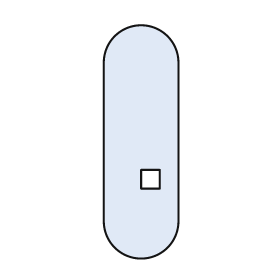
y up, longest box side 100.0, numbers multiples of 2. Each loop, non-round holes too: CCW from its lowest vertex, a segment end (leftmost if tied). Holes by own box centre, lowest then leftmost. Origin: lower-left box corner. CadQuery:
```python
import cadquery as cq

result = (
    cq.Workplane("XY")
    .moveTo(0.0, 16.0)
    .threePointArc((16.0, 0.0), (32.0, 16.0))
    .lineTo(32.0, 84.0)
    .threePointArc((16.0, 100.0), (0.0, 84.0))
    .close()
    .moveTo(16.0, 30.0)
    .lineTo(24.0, 30.0)
    .lineTo(24.0, 38.0)
    .lineTo(16.0, 38.0)
    .close()
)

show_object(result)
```